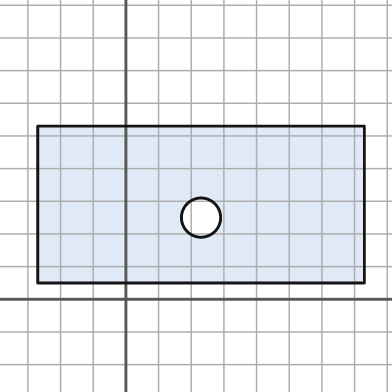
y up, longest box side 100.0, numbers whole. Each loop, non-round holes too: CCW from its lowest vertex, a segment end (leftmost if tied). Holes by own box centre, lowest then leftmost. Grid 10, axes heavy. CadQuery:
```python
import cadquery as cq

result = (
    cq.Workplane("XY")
    .moveTo(-27.0, 5.0)
    .lineTo(73.0, 5.0)
    .lineTo(73.0, 53.0)
    .lineTo(-27.0, 53.0)
    .close()
    .moveTo(23.0, 25.0)
    .circle(6.0)
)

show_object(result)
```